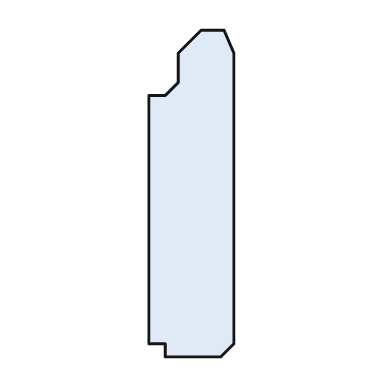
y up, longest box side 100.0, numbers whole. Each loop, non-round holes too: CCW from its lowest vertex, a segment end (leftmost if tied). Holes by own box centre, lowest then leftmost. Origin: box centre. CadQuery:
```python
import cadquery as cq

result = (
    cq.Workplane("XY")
    .moveTo(-8.0, -50.0)
    .lineTo(9.0, -50.0)
    .lineTo(13.0, -46.0)
    .lineTo(13.0, 43.0)
    .lineTo(10.0, 50.0)
    .lineTo(3.0, 50.0)
    .lineTo(-4.0, 43.0)
    .lineTo(-4.0, 34.0)
    .lineTo(-8.0, 30.0)
    .lineTo(-13.0, 30.0)
    .lineTo(-13.0, -46.0)
    .lineTo(-8.0, -46.0)
    .close()
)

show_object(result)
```